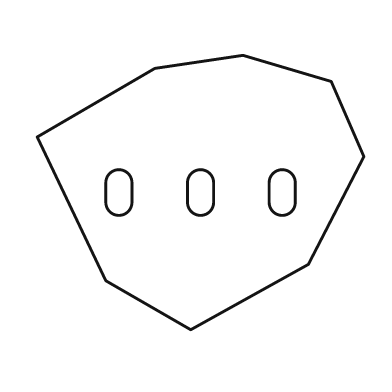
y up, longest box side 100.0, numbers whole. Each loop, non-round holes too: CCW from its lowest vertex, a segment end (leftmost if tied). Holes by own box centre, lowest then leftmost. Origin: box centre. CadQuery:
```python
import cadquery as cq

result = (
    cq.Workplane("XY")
    .moveTo(-3.0, -42.0)
    .lineTo(33.0, -22.0)
    .lineTo(50.0, 11.0)
    .lineTo(40.0, 34.0)
    .lineTo(13.0, 42.0)
    .lineTo(-14.0, 38.0)
    .lineTo(-50.0, 17.0)
    .lineTo(-29.0, -27.0)
    .close()
    .moveTo(-29.0, -3.0)
    .threePointArc((-25.0, -7.0), (-21.0, -3.0))
    .lineTo(-21.0, 3.0)
    .threePointArc((-25.0, 7.0), (-29.0, 3.0))
    .close()
    .moveTo(-4.0, -3.0)
    .threePointArc((0.0, -7.0), (4.0, -3.0))
    .lineTo(4.0, 3.0)
    .threePointArc((0.0, 7.0), (-4.0, 3.0))
    .close()
    .moveTo(21.0, -3.0)
    .threePointArc((25.0, -7.0), (29.0, -3.0))
    .lineTo(29.0, 3.0)
    .threePointArc((25.0, 7.0), (21.0, 3.0))
    .close()
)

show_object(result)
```